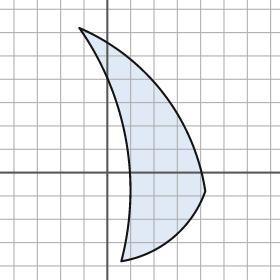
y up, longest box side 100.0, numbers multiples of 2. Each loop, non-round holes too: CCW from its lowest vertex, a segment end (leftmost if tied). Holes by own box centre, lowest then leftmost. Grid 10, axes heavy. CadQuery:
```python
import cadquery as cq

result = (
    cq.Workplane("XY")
    .moveTo(6.0, -38.0)
    .threePointArc((28.0, -28.0), (42.0, -8.0))
    .threePointArc((24.0, 34.0), (-12.0, 62.0))
    .threePointArc((8.0, 14.0), (6.0, -38.0))
    .close()
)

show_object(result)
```